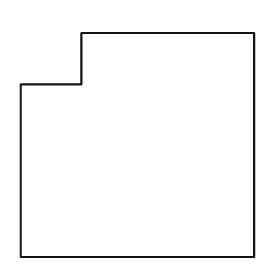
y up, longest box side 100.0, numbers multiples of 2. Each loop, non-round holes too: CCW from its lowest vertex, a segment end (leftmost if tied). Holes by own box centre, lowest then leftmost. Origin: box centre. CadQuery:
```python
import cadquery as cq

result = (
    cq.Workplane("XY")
    .moveTo(-50.0, -48.0)
    .lineTo(50.0, -48.0)
    .lineTo(50.0, 48.0)
    .lineTo(-24.0, 48.0)
    .lineTo(-24.0, 26.0)
    .lineTo(-50.0, 26.0)
    .close()
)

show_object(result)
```